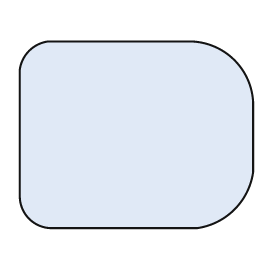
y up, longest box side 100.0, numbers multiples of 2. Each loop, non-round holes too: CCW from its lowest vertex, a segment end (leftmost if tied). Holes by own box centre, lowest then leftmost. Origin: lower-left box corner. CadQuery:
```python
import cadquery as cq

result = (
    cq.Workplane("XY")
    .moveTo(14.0, 0.0)
    .lineTo(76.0, 0.0)
    .threePointArc((92.0, 8.0), (100.0, 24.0))
    .lineTo(100.0, 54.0)
    .threePointArc((92.0, 72.0), (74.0, 80.0))
    .lineTo(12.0, 80.0)
    .threePointArc((4.0, 76.0), (0.0, 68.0))
    .lineTo(0.0, 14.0)
    .threePointArc((4.0, 4.0), (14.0, 0.0))
    .close()
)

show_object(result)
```